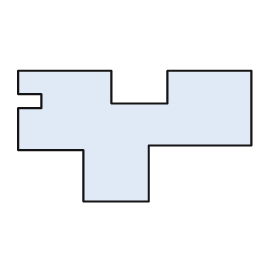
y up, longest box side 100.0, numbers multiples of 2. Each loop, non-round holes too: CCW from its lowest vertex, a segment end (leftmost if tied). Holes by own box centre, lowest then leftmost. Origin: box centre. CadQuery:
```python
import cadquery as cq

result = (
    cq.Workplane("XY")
    .moveTo(-22.0, -28.0)
    .lineTo(6.0, -28.0)
    .lineTo(6.0, -4.0)
    .lineTo(50.0, -4.0)
    .lineTo(50.0, 28.0)
    .lineTo(14.0, 28.0)
    .lineTo(14.0, 14.0)
    .lineTo(-10.0, 14.0)
    .lineTo(-10.0, 28.0)
    .lineTo(-50.0, 28.0)
    .lineTo(-50.0, 18.0)
    .lineTo(-40.0, 18.0)
    .lineTo(-40.0, 12.0)
    .lineTo(-50.0, 12.0)
    .lineTo(-50.0, -6.0)
    .lineTo(-22.0, -6.0)
    .close()
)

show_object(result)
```